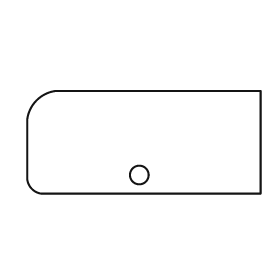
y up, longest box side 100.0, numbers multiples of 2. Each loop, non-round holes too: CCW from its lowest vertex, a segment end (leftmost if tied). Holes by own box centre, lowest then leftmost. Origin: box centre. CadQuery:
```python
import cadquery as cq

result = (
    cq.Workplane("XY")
    .moveTo(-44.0, -22.0)
    .lineTo(50.0, -22.0)
    .lineTo(50.0, 22.0)
    .lineTo(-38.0, 22.0)
    .threePointArc((-46.0, 18.0), (-50.0, 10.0))
    .lineTo(-50.0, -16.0)
    .threePointArc((-48.0, -20.0), (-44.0, -22.0))
    .close()
    .moveTo(-2.0, -14.0)
    .circle(4.0)
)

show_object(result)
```